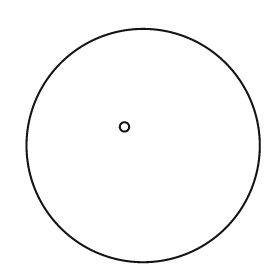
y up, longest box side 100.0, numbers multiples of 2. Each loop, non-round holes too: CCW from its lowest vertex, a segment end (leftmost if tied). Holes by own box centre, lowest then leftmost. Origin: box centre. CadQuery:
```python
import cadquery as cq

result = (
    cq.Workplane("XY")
    .moveTo(0.0, 0.0)
    .circle(50.0)
    .moveTo(-8.0, 8.0)
    .circle(2.0)
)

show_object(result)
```